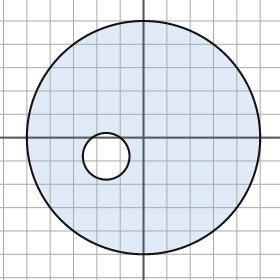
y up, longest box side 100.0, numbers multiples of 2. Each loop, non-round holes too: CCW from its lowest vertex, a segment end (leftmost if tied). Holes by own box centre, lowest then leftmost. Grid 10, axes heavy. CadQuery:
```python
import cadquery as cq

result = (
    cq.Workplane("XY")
    .moveTo(0.0, 0.0)
    .circle(50.0)
    .moveTo(-16.0, -8.0)
    .circle(10.0)
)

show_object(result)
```